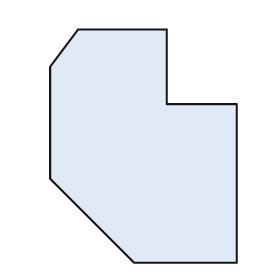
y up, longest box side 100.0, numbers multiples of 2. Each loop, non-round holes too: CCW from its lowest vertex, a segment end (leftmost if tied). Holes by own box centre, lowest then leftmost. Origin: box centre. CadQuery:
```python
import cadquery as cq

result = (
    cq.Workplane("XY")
    .moveTo(-4.0, -50.0)
    .lineTo(40.0, -50.0)
    .lineTo(40.0, 18.0)
    .lineTo(10.0, 18.0)
    .lineTo(10.0, 50.0)
    .lineTo(-28.0, 50.0)
    .lineTo(-40.0, 34.0)
    .lineTo(-40.0, -14.0)
    .close()
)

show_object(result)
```